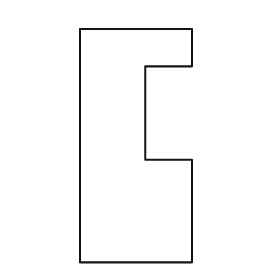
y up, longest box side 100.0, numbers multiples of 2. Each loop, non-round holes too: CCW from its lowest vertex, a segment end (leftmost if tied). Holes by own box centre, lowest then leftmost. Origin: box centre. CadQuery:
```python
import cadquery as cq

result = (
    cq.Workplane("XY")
    .moveTo(-24.0, -50.0)
    .lineTo(24.0, -50.0)
    .lineTo(24.0, -6.0)
    .lineTo(4.0, -6.0)
    .lineTo(4.0, 34.0)
    .lineTo(24.0, 34.0)
    .lineTo(24.0, 50.0)
    .lineTo(-24.0, 50.0)
    .close()
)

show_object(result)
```